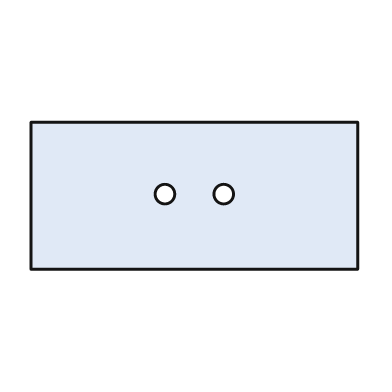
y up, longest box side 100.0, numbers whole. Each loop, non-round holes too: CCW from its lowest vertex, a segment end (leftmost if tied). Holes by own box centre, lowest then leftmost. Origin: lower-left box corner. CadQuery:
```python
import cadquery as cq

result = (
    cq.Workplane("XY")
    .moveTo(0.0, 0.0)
    .lineTo(100.0, 0.0)
    .lineTo(100.0, 45.0)
    .lineTo(0.0, 45.0)
    .close()
    .moveTo(41.0, 23.0)
    .circle(3.0)
    .moveTo(59.0, 23.0)
    .circle(3.0)
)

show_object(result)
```